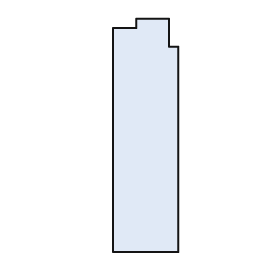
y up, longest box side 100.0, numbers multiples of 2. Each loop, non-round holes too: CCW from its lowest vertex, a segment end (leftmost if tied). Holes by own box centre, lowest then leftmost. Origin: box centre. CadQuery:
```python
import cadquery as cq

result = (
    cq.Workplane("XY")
    .moveTo(-14.0, -50.0)
    .lineTo(14.0, -50.0)
    .lineTo(14.0, 38.0)
    .lineTo(10.0, 38.0)
    .lineTo(10.0, 50.0)
    .lineTo(-4.0, 50.0)
    .lineTo(-4.0, 46.0)
    .lineTo(-14.0, 46.0)
    .close()
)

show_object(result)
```